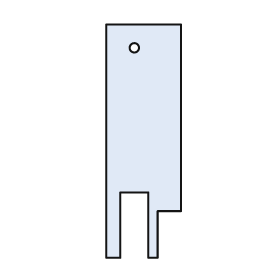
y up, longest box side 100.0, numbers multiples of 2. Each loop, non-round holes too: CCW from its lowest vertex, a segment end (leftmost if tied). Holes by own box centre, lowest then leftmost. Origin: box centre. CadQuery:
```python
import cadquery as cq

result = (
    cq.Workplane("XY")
    .moveTo(-16.0, -50.0)
    .lineTo(-10.0, -50.0)
    .lineTo(-10.0, -22.0)
    .lineTo(2.0, -22.0)
    .lineTo(2.0, -50.0)
    .lineTo(6.0, -50.0)
    .lineTo(6.0, -30.0)
    .lineTo(16.0, -30.0)
    .lineTo(16.0, 50.0)
    .lineTo(-16.0, 50.0)
    .close()
    .moveTo(-4.0, 40.0)
    .circle(2.0)
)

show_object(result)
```